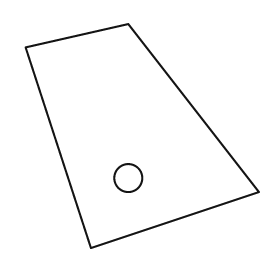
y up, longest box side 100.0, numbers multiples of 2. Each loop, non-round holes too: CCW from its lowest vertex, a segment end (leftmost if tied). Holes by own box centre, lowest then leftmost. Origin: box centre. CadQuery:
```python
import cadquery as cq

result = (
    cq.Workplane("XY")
    .moveTo(-22.0, -48.0)
    .lineTo(50.0, -24.0)
    .lineTo(-6.0, 48.0)
    .lineTo(-50.0, 38.0)
    .close()
    .moveTo(-6.0, -18.0)
    .circle(6.0)
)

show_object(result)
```